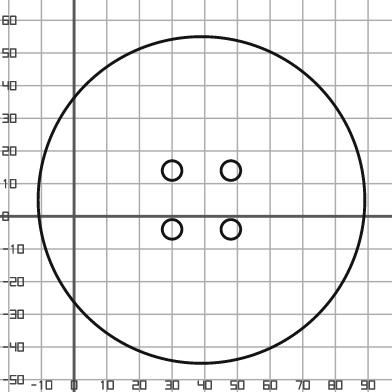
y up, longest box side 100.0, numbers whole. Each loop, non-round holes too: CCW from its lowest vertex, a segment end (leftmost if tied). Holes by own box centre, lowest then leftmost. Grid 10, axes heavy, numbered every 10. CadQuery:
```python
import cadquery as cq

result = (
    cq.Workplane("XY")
    .moveTo(39.0, 5.0)
    .circle(50.0)
    .moveTo(30.0, -4.0)
    .circle(3.0)
    .moveTo(48.0, -4.0)
    .circle(3.0)
    .moveTo(30.0, 14.0)
    .circle(3.0)
    .moveTo(48.0, 14.0)
    .circle(3.0)
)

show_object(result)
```